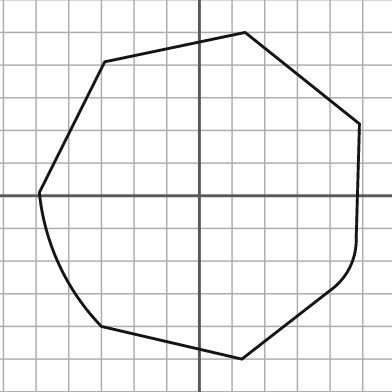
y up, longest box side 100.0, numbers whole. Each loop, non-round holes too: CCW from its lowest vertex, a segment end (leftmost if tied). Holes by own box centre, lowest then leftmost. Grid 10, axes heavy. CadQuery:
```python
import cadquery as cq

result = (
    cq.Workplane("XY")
    .moveTo(13.0, -50.0)
    .lineTo(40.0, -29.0)
    .threePointArc((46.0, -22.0), (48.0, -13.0))
    .lineTo(49.0, 22.0)
    .lineTo(14.0, 50.0)
    .lineTo(-29.0, 41.0)
    .lineTo(-49.0, 1.0)
    .threePointArc((-43.0, -21.0), (-30.0, -40.0))
    .close()
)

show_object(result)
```